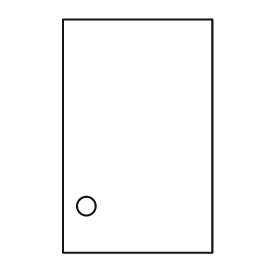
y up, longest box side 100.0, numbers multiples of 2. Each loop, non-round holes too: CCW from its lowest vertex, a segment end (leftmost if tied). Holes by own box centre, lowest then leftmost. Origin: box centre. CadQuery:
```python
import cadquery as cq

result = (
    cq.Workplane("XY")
    .moveTo(-32.0, -50.0)
    .lineTo(32.0, -50.0)
    .lineTo(32.0, 50.0)
    .lineTo(-32.0, 50.0)
    .close()
    .moveTo(-22.0, -30.0)
    .circle(4.0)
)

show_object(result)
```